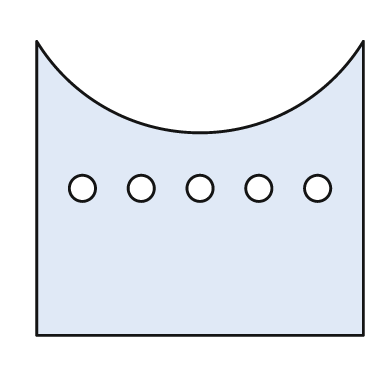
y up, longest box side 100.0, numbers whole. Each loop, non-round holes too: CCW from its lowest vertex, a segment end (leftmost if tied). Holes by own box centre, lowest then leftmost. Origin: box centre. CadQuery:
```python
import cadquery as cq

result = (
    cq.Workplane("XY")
    .moveTo(-50.0, -45.0)
    .lineTo(50.0, -45.0)
    .lineTo(50.0, 45.0)
    .threePointArc((0.0, 17.0), (-50.0, 45.0))
    .close()
    .moveTo(-36.0, 0.0)
    .circle(4.0)
    .moveTo(-18.0, 0.0)
    .circle(4.0)
    .moveTo(0.0, 0.0)
    .circle(4.0)
    .moveTo(18.0, 0.0)
    .circle(4.0)
    .moveTo(36.0, 0.0)
    .circle(4.0)
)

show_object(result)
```